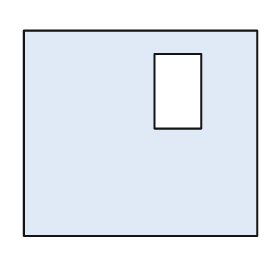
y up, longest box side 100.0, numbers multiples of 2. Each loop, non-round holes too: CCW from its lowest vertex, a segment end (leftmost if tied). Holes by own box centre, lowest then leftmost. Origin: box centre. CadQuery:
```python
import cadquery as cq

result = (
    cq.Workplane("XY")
    .moveTo(-50.0, -44.0)
    .lineTo(50.0, -44.0)
    .lineTo(50.0, 44.0)
    .lineTo(-50.0, 44.0)
    .close()
    .moveTo(6.0, 2.0)
    .lineTo(26.0, 2.0)
    .lineTo(26.0, 34.0)
    .lineTo(6.0, 34.0)
    .close()
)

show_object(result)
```